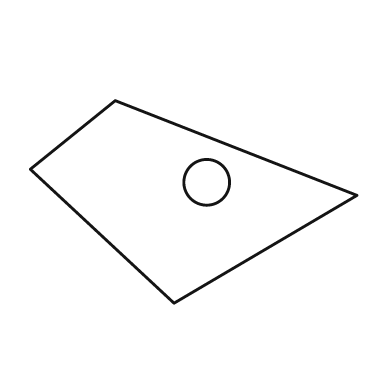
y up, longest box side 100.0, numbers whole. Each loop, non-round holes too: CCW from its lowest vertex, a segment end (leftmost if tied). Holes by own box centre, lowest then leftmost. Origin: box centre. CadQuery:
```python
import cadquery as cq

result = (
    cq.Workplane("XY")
    .moveTo(-6.0, -31.0)
    .lineTo(50.0, 2.0)
    .lineTo(-24.0, 31.0)
    .lineTo(-50.0, 10.0)
    .close()
    .moveTo(4.0, 6.0)
    .circle(7.0)
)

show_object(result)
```